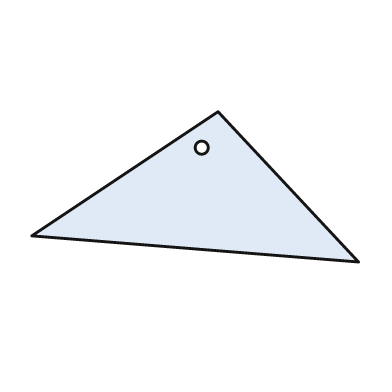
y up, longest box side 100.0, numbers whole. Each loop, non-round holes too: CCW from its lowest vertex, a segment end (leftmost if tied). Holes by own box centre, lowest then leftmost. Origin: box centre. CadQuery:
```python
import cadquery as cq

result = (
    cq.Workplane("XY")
    .moveTo(50.0, -23.0)
    .lineTo(7.0, 23.0)
    .lineTo(-50.0, -15.0)
    .close()
    .moveTo(2.0, 12.0)
    .circle(2.0)
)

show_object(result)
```